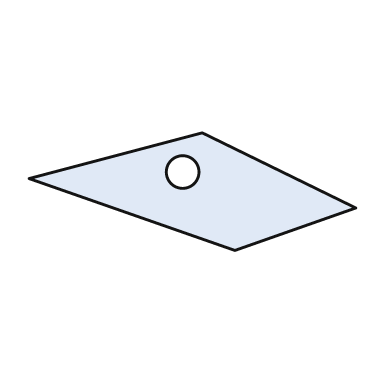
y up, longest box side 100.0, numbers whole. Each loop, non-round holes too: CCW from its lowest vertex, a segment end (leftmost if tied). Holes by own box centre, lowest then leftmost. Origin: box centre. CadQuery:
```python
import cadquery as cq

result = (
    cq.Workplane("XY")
    .moveTo(13.0, -18.0)
    .lineTo(50.0, -5.0)
    .lineTo(3.0, 18.0)
    .lineTo(-50.0, 4.0)
    .close()
    .moveTo(-3.0, 6.0)
    .circle(5.0)
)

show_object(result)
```